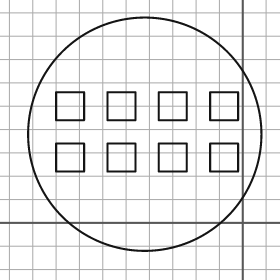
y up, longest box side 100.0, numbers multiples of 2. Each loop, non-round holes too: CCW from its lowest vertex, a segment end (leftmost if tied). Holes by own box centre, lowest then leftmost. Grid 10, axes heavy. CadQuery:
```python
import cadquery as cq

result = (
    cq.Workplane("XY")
    .moveTo(-42.0, 38.0)
    .circle(50.0)
    .moveTo(-80.0, 22.0)
    .lineTo(-68.0, 22.0)
    .lineTo(-68.0, 34.0)
    .lineTo(-80.0, 34.0)
    .close()
    .moveTo(-58.0, 22.0)
    .lineTo(-46.0, 22.0)
    .lineTo(-46.0, 34.0)
    .lineTo(-58.0, 34.0)
    .close()
    .moveTo(-36.0, 22.0)
    .lineTo(-24.0, 22.0)
    .lineTo(-24.0, 34.0)
    .lineTo(-36.0, 34.0)
    .close()
    .moveTo(-14.0, 22.0)
    .lineTo(-2.0, 22.0)
    .lineTo(-2.0, 34.0)
    .lineTo(-14.0, 34.0)
    .close()
    .moveTo(-80.0, 44.0)
    .lineTo(-68.0, 44.0)
    .lineTo(-68.0, 56.0)
    .lineTo(-80.0, 56.0)
    .close()
    .moveTo(-58.0, 44.0)
    .lineTo(-46.0, 44.0)
    .lineTo(-46.0, 56.0)
    .lineTo(-58.0, 56.0)
    .close()
    .moveTo(-36.0, 44.0)
    .lineTo(-24.0, 44.0)
    .lineTo(-24.0, 56.0)
    .lineTo(-36.0, 56.0)
    .close()
    .moveTo(-14.0, 44.0)
    .lineTo(-2.0, 44.0)
    .lineTo(-2.0, 56.0)
    .lineTo(-14.0, 56.0)
    .close()
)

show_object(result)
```